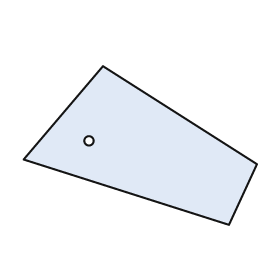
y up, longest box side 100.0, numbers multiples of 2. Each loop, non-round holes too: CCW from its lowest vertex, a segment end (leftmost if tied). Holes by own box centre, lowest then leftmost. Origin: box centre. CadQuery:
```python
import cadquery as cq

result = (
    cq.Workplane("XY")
    .moveTo(38.0, -34.0)
    .lineTo(50.0, -8.0)
    .lineTo(-16.0, 34.0)
    .lineTo(-50.0, -6.0)
    .close()
    .moveTo(-22.0, 2.0)
    .circle(2.0)
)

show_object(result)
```